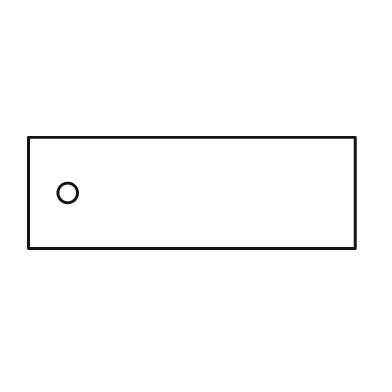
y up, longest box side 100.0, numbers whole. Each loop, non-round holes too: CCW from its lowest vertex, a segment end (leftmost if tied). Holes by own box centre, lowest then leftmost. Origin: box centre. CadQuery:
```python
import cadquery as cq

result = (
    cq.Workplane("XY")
    .moveTo(-50.0, -17.0)
    .lineTo(50.0, -17.0)
    .lineTo(50.0, 17.0)
    .lineTo(-50.0, 17.0)
    .close()
    .moveTo(-38.0, 0.0)
    .circle(3.0)
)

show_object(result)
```